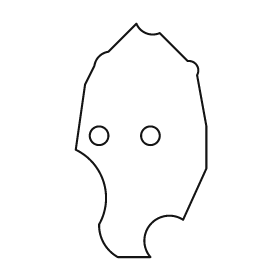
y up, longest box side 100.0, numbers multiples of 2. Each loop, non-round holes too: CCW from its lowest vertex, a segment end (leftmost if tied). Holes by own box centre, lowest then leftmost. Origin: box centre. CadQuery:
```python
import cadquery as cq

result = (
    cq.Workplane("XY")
    .moveTo(-10.0, -50.0)
    .lineTo(4.0, -50.0)
    .threePointArc((4.0, -36.0), (18.0, -34.0))
    .lineTo(28.0, -12.0)
    .lineTo(28.0, 6.0)
    .lineTo(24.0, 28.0)
    .threePointArc((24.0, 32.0), (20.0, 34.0))
    .lineTo(8.0, 46.0)
    .threePointArc((2.0, 46.0), (-2.0, 50.0))
    .lineTo(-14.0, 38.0)
    .threePointArc((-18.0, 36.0), (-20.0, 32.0))
    .lineTo(-24.0, 24.0)
    .lineTo(-28.0, -4.0)
    .threePointArc((-16.0, -18.0), (-18.0, -36.0))
    .threePointArc((-16.0, -44.0), (-10.0, -50.0))
    .close()
    .moveTo(-18.0, 2.0)
    .circle(4.0)
    .moveTo(4.0, 2.0)
    .circle(4.0)
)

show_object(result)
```